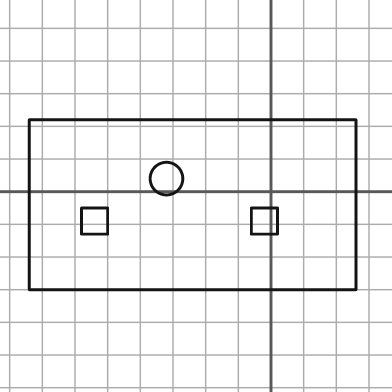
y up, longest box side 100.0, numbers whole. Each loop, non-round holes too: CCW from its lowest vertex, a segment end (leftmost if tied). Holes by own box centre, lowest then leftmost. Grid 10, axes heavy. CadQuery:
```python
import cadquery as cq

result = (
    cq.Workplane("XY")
    .moveTo(-74.0, -30.0)
    .lineTo(26.0, -30.0)
    .lineTo(26.0, 22.0)
    .lineTo(-74.0, 22.0)
    .close()
    .moveTo(-58.0, -13.0)
    .lineTo(-50.0, -13.0)
    .lineTo(-50.0, -5.0)
    .lineTo(-58.0, -5.0)
    .close()
    .moveTo(-6.0, -13.0)
    .lineTo(2.0, -13.0)
    .lineTo(2.0, -5.0)
    .lineTo(-6.0, -5.0)
    .close()
    .moveTo(-32.0, 4.0)
    .circle(5.0)
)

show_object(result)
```